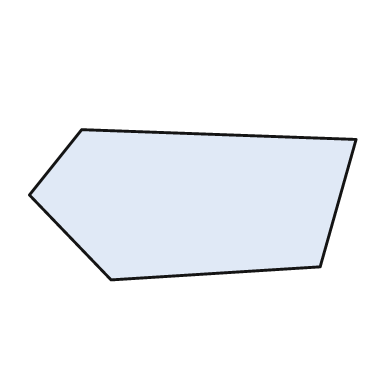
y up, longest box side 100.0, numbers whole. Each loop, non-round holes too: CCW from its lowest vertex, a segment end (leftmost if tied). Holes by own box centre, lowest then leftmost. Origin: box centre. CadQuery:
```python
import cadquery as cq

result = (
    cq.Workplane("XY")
    .moveTo(-25.0, -23.0)
    .lineTo(39.0, -19.0)
    .lineTo(50.0, 20.0)
    .lineTo(-34.0, 23.0)
    .lineTo(-50.0, 3.0)
    .close()
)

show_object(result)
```